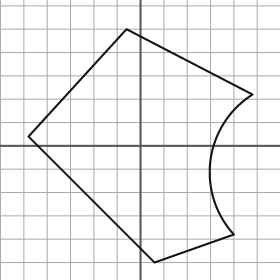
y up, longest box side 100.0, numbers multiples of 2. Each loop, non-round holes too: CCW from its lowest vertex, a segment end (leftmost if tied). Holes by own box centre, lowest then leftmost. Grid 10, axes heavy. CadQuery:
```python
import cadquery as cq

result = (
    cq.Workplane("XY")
    .moveTo(6.0, -50.0)
    .lineTo(40.0, -38.0)
    .threePointArc((30.0, -6.0), (48.0, 22.0))
    .lineTo(-6.0, 50.0)
    .lineTo(-48.0, 4.0)
    .close()
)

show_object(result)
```